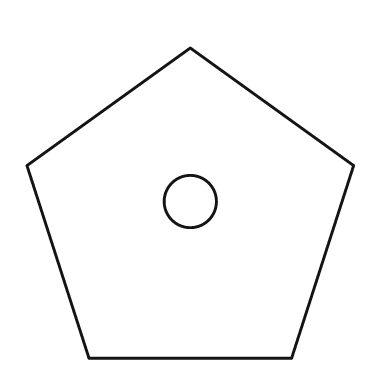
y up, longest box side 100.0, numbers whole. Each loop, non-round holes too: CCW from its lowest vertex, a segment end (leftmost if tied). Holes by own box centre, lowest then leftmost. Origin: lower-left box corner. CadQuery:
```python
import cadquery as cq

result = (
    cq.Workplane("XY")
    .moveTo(19.0, 0.0)
    .lineTo(81.0, 0.0)
    .lineTo(100.0, 59.0)
    .lineTo(50.0, 95.0)
    .lineTo(0.0, 59.0)
    .close()
    .moveTo(50.0, 48.0)
    .circle(8.0)
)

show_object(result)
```